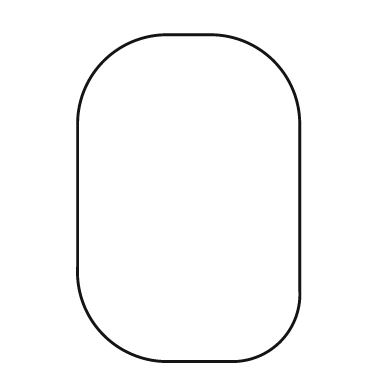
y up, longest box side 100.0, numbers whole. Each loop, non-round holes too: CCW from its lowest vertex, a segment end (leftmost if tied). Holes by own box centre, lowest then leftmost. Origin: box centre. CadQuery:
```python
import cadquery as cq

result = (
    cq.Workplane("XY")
    .moveTo(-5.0, -50.0)
    .lineTo(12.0, -50.0)
    .threePointArc((28.0, -44.0), (34.0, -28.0))
    .lineTo(34.0, 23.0)
    .threePointArc((26.0, 42.0), (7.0, 50.0))
    .lineTo(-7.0, 50.0)
    .threePointArc((-26.0, 42.0), (-34.0, 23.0))
    .lineTo(-34.0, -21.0)
    .threePointArc((-26.0, -42.0), (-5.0, -50.0))
    .close()
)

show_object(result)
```